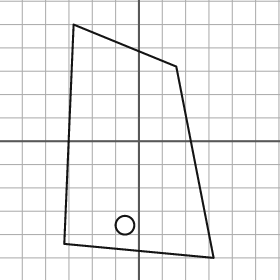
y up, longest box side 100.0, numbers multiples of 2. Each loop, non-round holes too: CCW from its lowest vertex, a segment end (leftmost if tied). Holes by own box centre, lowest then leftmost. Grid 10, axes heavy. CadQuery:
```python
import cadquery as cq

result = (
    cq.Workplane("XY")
    .moveTo(32.0, -50.0)
    .lineTo(16.0, 32.0)
    .lineTo(-28.0, 50.0)
    .lineTo(-32.0, -44.0)
    .close()
    .moveTo(-6.0, -36.0)
    .circle(4.0)
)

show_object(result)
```